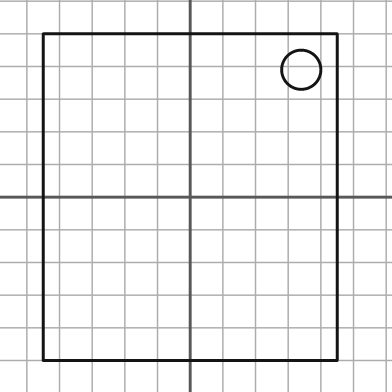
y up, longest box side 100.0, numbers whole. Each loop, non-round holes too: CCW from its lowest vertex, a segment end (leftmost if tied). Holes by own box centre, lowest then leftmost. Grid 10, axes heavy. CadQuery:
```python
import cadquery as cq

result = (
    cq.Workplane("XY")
    .moveTo(-45.0, -50.0)
    .lineTo(45.0, -50.0)
    .lineTo(45.0, 50.0)
    .lineTo(-45.0, 50.0)
    .close()
    .moveTo(34.0, 39.0)
    .circle(6.0)
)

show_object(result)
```